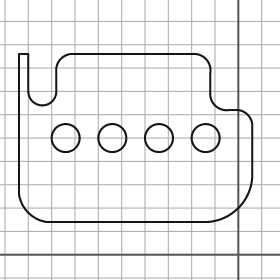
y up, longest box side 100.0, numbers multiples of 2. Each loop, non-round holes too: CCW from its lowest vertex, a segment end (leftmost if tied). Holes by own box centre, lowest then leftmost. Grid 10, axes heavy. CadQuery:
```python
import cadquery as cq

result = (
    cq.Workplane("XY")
    .moveTo(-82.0, 14.0)
    .lineTo(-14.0, 14.0)
    .threePointArc((0.0, 20.0), (6.0, 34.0))
    .lineTo(6.0, 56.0)
    .threePointArc((4.0, 60.0), (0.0, 62.0))
    .lineTo(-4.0, 62.0)
    .threePointArc((-10.0, 64.0), (-12.0, 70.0))
    .lineTo(-12.0, 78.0)
    .threePointArc((-14.0, 84.0), (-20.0, 86.0))
    .lineTo(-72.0, 86.0)
    .threePointArc((-76.0, 84.0), (-78.0, 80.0))
    .lineTo(-78.0, 70.0)
    .threePointArc((-84.0, 64.0), (-90.0, 70.0))
    .lineTo(-90.0, 86.0)
    .lineTo(-94.0, 86.0)
    .lineTo(-94.0, 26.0)
    .threePointArc((-90.0, 18.0), (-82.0, 14.0))
    .close()
    .moveTo(-74.0, 50.0)
    .circle(6.0)
    .moveTo(-54.0, 50.0)
    .circle(6.0)
    .moveTo(-34.0, 50.0)
    .circle(6.0)
    .moveTo(-14.0, 50.0)
    .circle(6.0)
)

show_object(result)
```